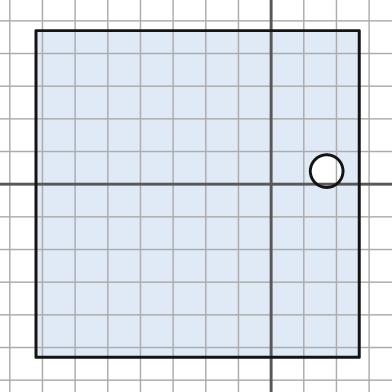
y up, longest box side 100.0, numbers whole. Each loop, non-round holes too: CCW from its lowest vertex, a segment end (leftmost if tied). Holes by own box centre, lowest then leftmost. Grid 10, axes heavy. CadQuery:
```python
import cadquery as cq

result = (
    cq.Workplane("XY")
    .moveTo(-72.0, -53.0)
    .lineTo(27.0, -53.0)
    .lineTo(27.0, 47.0)
    .lineTo(-72.0, 47.0)
    .close()
    .moveTo(17.0, 4.0)
    .circle(5.0)
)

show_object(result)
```